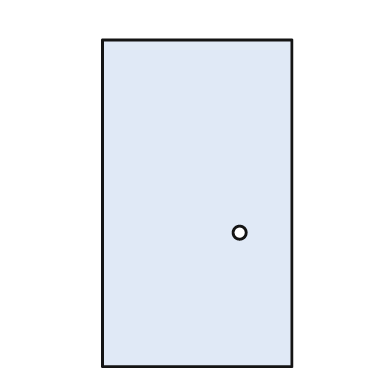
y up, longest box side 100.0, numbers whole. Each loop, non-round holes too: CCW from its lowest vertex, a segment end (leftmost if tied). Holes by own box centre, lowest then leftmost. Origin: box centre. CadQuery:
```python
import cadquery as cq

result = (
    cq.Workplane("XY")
    .moveTo(-29.0, -50.0)
    .lineTo(29.0, -50.0)
    .lineTo(29.0, 50.0)
    .lineTo(-29.0, 50.0)
    .close()
    .moveTo(13.0, -9.0)
    .circle(2.0)
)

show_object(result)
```